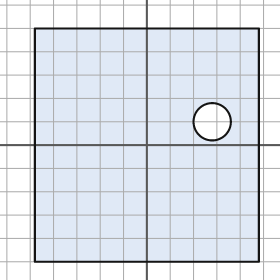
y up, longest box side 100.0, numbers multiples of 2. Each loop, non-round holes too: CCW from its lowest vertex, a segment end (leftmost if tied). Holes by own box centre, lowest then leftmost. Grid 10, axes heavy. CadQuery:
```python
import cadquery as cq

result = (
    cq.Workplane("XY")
    .moveTo(-48.0, -50.0)
    .lineTo(48.0, -50.0)
    .lineTo(48.0, 50.0)
    .lineTo(-48.0, 50.0)
    .close()
    .moveTo(28.0, 10.0)
    .circle(8.0)
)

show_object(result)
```